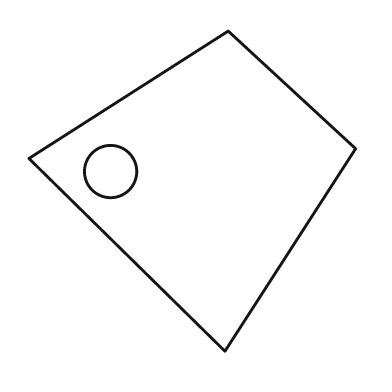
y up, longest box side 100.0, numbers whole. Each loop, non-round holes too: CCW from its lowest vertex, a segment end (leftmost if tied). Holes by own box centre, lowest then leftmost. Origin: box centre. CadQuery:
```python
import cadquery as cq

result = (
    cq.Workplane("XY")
    .moveTo(10.0, -49.0)
    .lineTo(50.0, 13.0)
    .lineTo(11.0, 49.0)
    .lineTo(-50.0, 10.0)
    .close()
    .moveTo(-25.0, 6.0)
    .circle(8.0)
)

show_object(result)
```